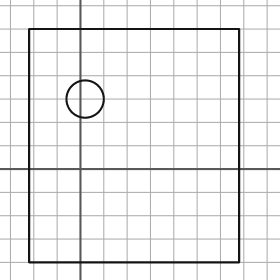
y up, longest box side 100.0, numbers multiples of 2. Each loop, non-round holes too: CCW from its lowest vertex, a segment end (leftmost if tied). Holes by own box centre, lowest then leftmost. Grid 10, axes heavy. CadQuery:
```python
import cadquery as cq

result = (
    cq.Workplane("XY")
    .moveTo(-22.0, -40.0)
    .lineTo(68.0, -40.0)
    .lineTo(68.0, 60.0)
    .lineTo(-22.0, 60.0)
    .close()
    .moveTo(2.0, 30.0)
    .circle(8.0)
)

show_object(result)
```